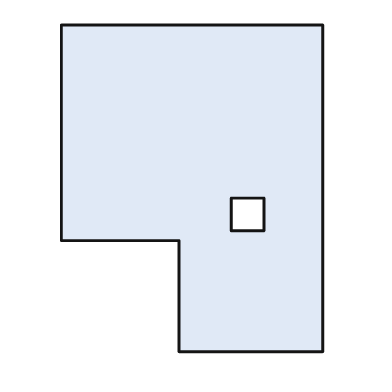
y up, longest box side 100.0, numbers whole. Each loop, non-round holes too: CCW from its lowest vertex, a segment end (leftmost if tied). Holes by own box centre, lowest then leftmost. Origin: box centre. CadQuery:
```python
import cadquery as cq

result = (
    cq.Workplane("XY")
    .moveTo(-4.0, -50.0)
    .lineTo(40.0, -50.0)
    .lineTo(40.0, 50.0)
    .lineTo(-40.0, 50.0)
    .lineTo(-40.0, -16.0)
    .lineTo(-4.0, -16.0)
    .close()
    .moveTo(12.0, -13.0)
    .lineTo(22.0, -13.0)
    .lineTo(22.0, -3.0)
    .lineTo(12.0, -3.0)
    .close()
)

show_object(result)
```